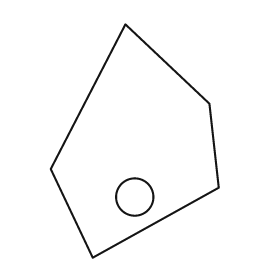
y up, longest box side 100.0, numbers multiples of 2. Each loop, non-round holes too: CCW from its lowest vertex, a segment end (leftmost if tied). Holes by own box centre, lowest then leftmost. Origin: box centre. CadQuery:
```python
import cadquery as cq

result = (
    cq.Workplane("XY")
    .moveTo(-18.0, -50.0)
    .lineTo(36.0, -20.0)
    .lineTo(32.0, 16.0)
    .lineTo(-4.0, 50.0)
    .lineTo(-36.0, -12.0)
    .close()
    .moveTo(0.0, -24.0)
    .circle(8.0)
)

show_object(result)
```